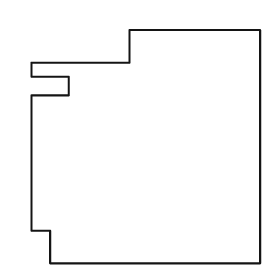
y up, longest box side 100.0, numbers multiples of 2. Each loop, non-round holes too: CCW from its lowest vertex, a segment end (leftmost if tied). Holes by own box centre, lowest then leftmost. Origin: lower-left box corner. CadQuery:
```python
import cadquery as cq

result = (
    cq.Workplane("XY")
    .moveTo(8.0, 0.0)
    .lineTo(98.0, 0.0)
    .lineTo(98.0, 100.0)
    .lineTo(42.0, 100.0)
    .lineTo(42.0, 86.0)
    .lineTo(0.0, 86.0)
    .lineTo(0.0, 80.0)
    .lineTo(16.0, 80.0)
    .lineTo(16.0, 72.0)
    .lineTo(0.0, 72.0)
    .lineTo(0.0, 14.0)
    .lineTo(8.0, 14.0)
    .close()
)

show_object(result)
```